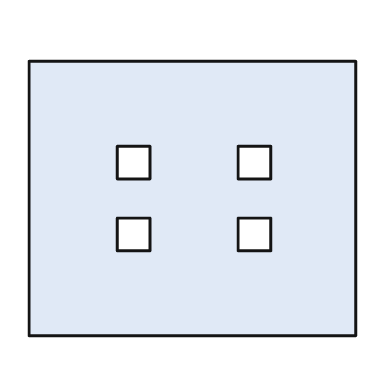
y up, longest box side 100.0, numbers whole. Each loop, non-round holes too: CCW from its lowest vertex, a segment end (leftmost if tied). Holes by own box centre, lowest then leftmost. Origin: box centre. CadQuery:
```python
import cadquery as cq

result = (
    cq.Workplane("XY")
    .moveTo(-50.0, -42.0)
    .lineTo(50.0, -42.0)
    .lineTo(50.0, 42.0)
    .lineTo(-50.0, 42.0)
    .close()
    .moveTo(-23.0, -16.0)
    .lineTo(-13.0, -16.0)
    .lineTo(-13.0, -6.0)
    .lineTo(-23.0, -6.0)
    .close()
    .moveTo(14.0, -16.0)
    .lineTo(24.0, -16.0)
    .lineTo(24.0, -6.0)
    .lineTo(14.0, -6.0)
    .close()
    .moveTo(-23.0, 6.0)
    .lineTo(-13.0, 6.0)
    .lineTo(-13.0, 16.0)
    .lineTo(-23.0, 16.0)
    .close()
    .moveTo(14.0, 6.0)
    .lineTo(24.0, 6.0)
    .lineTo(24.0, 16.0)
    .lineTo(14.0, 16.0)
    .close()
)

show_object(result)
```